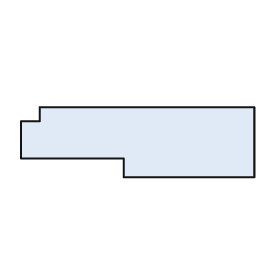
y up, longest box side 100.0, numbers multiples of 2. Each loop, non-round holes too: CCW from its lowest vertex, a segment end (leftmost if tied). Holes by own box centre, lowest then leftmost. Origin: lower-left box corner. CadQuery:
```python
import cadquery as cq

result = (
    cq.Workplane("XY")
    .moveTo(44.0, 0.0)
    .lineTo(100.0, 0.0)
    .lineTo(100.0, 30.0)
    .lineTo(8.0, 30.0)
    .lineTo(8.0, 24.0)
    .lineTo(0.0, 24.0)
    .lineTo(0.0, 8.0)
    .lineTo(44.0, 8.0)
    .close()
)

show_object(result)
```